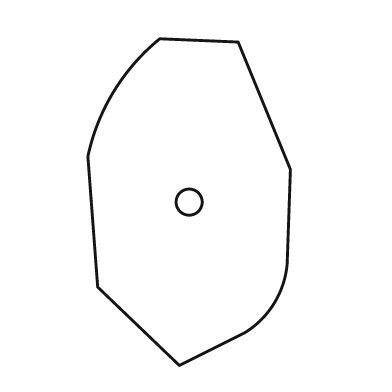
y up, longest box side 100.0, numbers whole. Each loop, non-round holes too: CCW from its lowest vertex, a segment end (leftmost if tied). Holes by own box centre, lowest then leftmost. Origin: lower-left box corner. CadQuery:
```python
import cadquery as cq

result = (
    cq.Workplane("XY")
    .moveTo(28.0, 0.0)
    .lineTo(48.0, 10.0)
    .threePointArc((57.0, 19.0), (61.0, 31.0))
    .lineTo(62.0, 60.0)
    .lineTo(46.0, 99.0)
    .lineTo(22.0, 100.0)
    .threePointArc((8.0, 84.0), (0.0, 64.0))
    .lineTo(3.0, 24.0)
    .close()
    .moveTo(31.0, 50.0)
    .circle(4.0)
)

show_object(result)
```